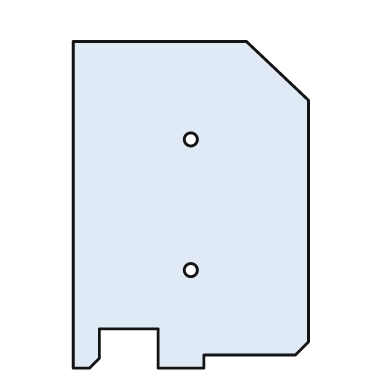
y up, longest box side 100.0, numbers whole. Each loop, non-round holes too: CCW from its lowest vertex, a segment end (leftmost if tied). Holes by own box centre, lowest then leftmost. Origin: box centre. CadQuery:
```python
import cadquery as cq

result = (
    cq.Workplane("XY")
    .moveTo(-36.0, -50.0)
    .lineTo(-31.0, -50.0)
    .lineTo(-28.0, -47.0)
    .lineTo(-28.0, -38.0)
    .lineTo(-10.0, -38.0)
    .lineTo(-10.0, -50.0)
    .lineTo(4.0, -50.0)
    .lineTo(4.0, -46.0)
    .lineTo(32.0, -46.0)
    .lineTo(36.0, -42.0)
    .lineTo(36.0, 32.0)
    .lineTo(17.0, 50.0)
    .lineTo(-36.0, 50.0)
    .close()
    .moveTo(0.0, -20.0)
    .circle(2.0)
    .moveTo(0.0, 20.0)
    .circle(2.0)
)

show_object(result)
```